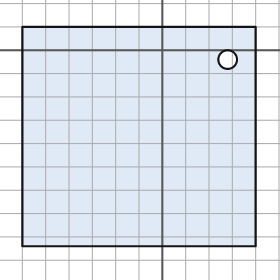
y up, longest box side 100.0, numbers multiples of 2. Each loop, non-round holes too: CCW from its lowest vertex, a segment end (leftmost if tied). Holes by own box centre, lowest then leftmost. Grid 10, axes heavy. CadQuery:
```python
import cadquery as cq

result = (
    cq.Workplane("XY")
    .moveTo(-60.0, -84.0)
    .lineTo(40.0, -84.0)
    .lineTo(40.0, 10.0)
    .lineTo(-60.0, 10.0)
    .close()
    .moveTo(28.0, -4.0)
    .circle(4.0)
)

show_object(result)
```